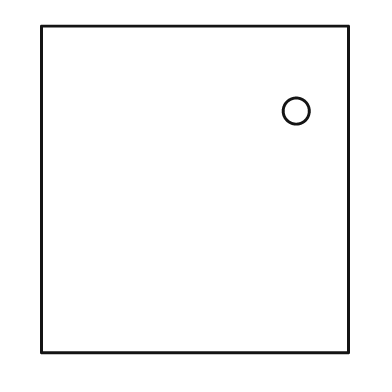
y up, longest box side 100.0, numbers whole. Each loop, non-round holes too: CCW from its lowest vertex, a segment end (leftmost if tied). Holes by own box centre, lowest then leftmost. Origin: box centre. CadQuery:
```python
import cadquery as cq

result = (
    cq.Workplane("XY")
    .moveTo(-47.0, -50.0)
    .lineTo(47.0, -50.0)
    .lineTo(47.0, 50.0)
    .lineTo(-47.0, 50.0)
    .close()
    .moveTo(31.0, 24.0)
    .circle(4.0)
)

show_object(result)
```